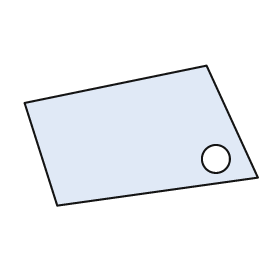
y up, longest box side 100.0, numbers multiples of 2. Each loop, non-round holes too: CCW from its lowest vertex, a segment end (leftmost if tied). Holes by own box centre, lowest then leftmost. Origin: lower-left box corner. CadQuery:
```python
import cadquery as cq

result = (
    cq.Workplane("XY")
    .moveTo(14.0, 0.0)
    .lineTo(100.0, 12.0)
    .lineTo(78.0, 60.0)
    .lineTo(0.0, 44.0)
    .close()
    .moveTo(82.0, 20.0)
    .circle(6.0)
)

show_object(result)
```